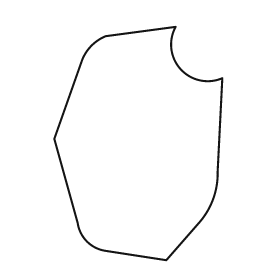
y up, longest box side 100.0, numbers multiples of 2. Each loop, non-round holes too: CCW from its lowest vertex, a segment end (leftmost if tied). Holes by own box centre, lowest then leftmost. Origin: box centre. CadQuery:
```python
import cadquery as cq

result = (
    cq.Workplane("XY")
    .moveTo(12.0, -50.0)
    .lineTo(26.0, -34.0)
    .threePointArc((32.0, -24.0), (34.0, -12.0))
    .lineTo(36.0, 28.0)
    .threePointArc((18.0, 32.0), (16.0, 50.0))
    .lineTo(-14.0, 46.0)
    .threePointArc((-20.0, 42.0), (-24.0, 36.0))
    .lineTo(-36.0, 2.0)
    .lineTo(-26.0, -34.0)
    .threePointArc((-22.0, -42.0), (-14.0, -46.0))
    .close()
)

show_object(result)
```